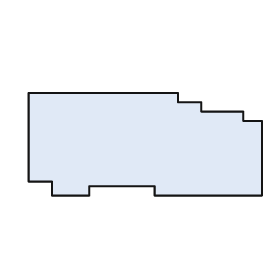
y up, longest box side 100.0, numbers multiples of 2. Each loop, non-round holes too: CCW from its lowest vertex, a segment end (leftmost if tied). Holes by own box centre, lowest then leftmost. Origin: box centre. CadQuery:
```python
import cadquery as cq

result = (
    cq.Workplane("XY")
    .moveTo(-40.0, -22.0)
    .lineTo(-24.0, -22.0)
    .lineTo(-24.0, -18.0)
    .lineTo(4.0, -18.0)
    .lineTo(4.0, -22.0)
    .lineTo(50.0, -22.0)
    .lineTo(50.0, 10.0)
    .lineTo(42.0, 10.0)
    .lineTo(42.0, 14.0)
    .lineTo(24.0, 14.0)
    .lineTo(24.0, 18.0)
    .lineTo(14.0, 18.0)
    .lineTo(14.0, 22.0)
    .lineTo(-50.0, 22.0)
    .lineTo(-50.0, -16.0)
    .lineTo(-40.0, -16.0)
    .close()
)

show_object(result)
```